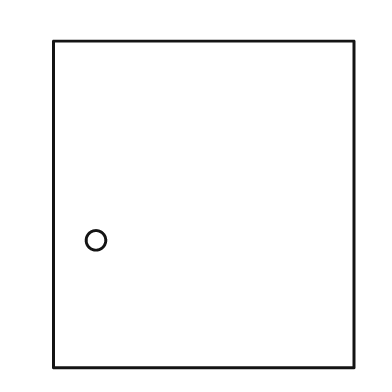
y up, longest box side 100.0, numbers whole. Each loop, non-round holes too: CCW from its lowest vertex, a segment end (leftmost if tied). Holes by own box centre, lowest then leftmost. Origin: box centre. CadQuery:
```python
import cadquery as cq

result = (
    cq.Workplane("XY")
    .moveTo(-46.0, -50.0)
    .lineTo(46.0, -50.0)
    .lineTo(46.0, 50.0)
    .lineTo(-46.0, 50.0)
    .close()
    .moveTo(-33.0, -11.0)
    .circle(3.0)
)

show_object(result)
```